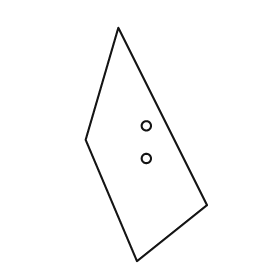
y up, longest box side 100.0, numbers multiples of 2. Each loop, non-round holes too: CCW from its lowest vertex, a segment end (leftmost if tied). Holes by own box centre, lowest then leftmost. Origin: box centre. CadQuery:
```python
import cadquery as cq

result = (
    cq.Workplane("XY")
    .moveTo(-4.0, -50.0)
    .lineTo(26.0, -26.0)
    .lineTo(-12.0, 50.0)
    .lineTo(-26.0, 2.0)
    .close()
    .moveTo(0.0, -6.0)
    .circle(2.0)
    .moveTo(0.0, 8.0)
    .circle(2.0)
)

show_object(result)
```